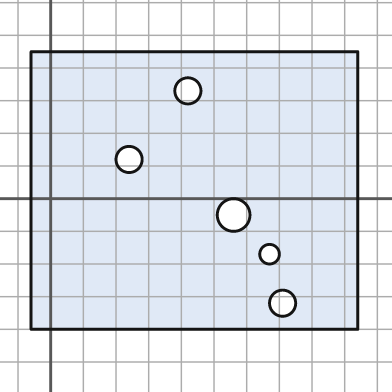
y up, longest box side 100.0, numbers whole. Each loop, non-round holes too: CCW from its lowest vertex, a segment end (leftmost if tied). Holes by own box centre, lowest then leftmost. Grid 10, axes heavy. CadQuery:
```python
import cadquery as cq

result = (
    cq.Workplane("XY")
    .moveTo(-6.0, -40.0)
    .lineTo(94.0, -40.0)
    .lineTo(94.0, 45.0)
    .lineTo(-6.0, 45.0)
    .close()
    .moveTo(71.0, -32.0)
    .circle(4.0)
    .moveTo(67.0, -17.0)
    .circle(3.0)
    .moveTo(56.0, -5.0)
    .circle(5.0)
    .moveTo(24.0, 12.0)
    .circle(4.0)
    .moveTo(42.0, 33.0)
    .circle(4.0)
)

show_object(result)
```